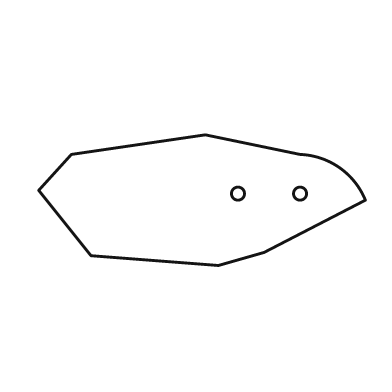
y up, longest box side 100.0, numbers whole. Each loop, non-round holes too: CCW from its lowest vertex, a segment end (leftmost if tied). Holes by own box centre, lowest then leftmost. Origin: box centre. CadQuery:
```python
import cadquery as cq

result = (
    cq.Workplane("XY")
    .moveTo(5.0, -20.0)
    .lineTo(19.0, -16.0)
    .lineTo(50.0, 0.0)
    .threePointArc((42.0, 10.0), (30.0, 14.0))
    .lineTo(1.0, 20.0)
    .lineTo(-40.0, 14.0)
    .lineTo(-50.0, 3.0)
    .lineTo(-34.0, -17.0)
    .close()
    .moveTo(11.0, 2.0)
    .circle(2.0)
    .moveTo(30.0, 2.0)
    .circle(2.0)
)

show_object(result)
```